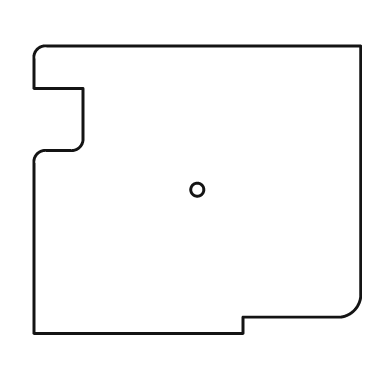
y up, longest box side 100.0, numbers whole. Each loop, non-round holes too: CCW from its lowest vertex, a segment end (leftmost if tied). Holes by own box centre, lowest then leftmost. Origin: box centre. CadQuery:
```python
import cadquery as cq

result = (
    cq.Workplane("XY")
    .moveTo(-50.0, -44.0)
    .lineTo(14.0, -44.0)
    .lineTo(14.0, -39.0)
    .lineTo(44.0, -39.0)
    .threePointArc((48.0, -37.0), (50.0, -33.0))
    .lineTo(50.0, 44.0)
    .lineTo(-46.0, 44.0)
    .threePointArc((-49.0, 43.0), (-50.0, 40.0))
    .lineTo(-50.0, 31.0)
    .lineTo(-35.0, 31.0)
    .lineTo(-35.0, 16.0)
    .threePointArc((-36.0, 13.0), (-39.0, 12.0))
    .lineTo(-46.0, 12.0)
    .threePointArc((-49.0, 11.0), (-50.0, 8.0))
    .close()
    .moveTo(0.0, 0.0)
    .circle(2.0)
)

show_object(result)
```